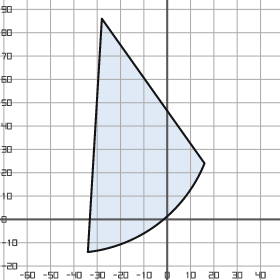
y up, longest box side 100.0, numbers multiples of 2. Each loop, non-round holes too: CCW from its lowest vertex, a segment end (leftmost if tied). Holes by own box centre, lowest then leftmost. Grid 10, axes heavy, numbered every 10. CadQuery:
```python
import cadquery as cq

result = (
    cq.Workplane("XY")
    .moveTo(-34.0, -14.0)
    .threePointArc((-4.0, -2.0), (16.0, 24.0))
    .lineTo(-28.0, 86.0)
    .close()
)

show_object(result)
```